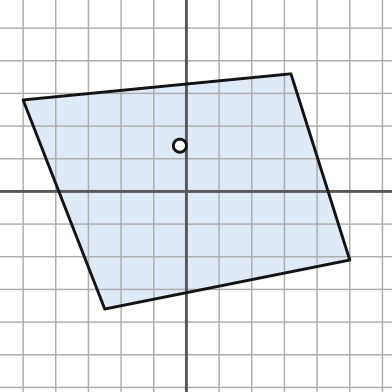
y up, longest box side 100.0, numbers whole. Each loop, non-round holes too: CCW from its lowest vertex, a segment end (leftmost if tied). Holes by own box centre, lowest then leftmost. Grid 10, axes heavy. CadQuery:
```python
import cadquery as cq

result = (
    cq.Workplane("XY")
    .moveTo(-25.0, -36.0)
    .lineTo(50.0, -21.0)
    .lineTo(32.0, 36.0)
    .lineTo(-50.0, 28.0)
    .close()
    .moveTo(-2.0, 14.0)
    .circle(2.0)
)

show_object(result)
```